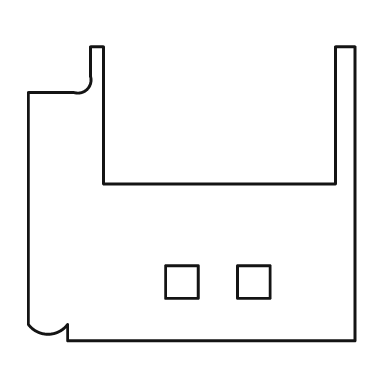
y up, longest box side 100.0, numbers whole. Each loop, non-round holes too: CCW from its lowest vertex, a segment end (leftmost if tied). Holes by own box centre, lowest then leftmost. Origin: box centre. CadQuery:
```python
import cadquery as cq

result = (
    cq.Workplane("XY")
    .moveTo(-38.0, -45.0)
    .lineTo(50.0, -45.0)
    .lineTo(50.0, 45.0)
    .lineTo(44.0, 45.0)
    .lineTo(44.0, 3.0)
    .lineTo(-27.0, 3.0)
    .lineTo(-27.0, 45.0)
    .lineTo(-31.0, 45.0)
    .lineTo(-31.0, 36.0)
    .threePointArc((-32.0, 32.0), (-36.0, 31.0))
    .lineTo(-50.0, 31.0)
    .lineTo(-50.0, -40.0)
    .threePointArc((-44.0, -43.0), (-38.0, -40.0))
    .close()
    .moveTo(-8.0, -32.0)
    .lineTo(2.0, -32.0)
    .lineTo(2.0, -22.0)
    .lineTo(-8.0, -22.0)
    .close()
    .moveTo(14.0, -32.0)
    .lineTo(24.0, -32.0)
    .lineTo(24.0, -22.0)
    .lineTo(14.0, -22.0)
    .close()
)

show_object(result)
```